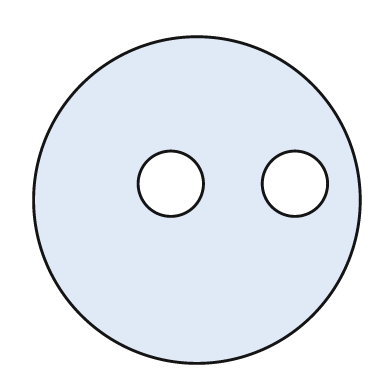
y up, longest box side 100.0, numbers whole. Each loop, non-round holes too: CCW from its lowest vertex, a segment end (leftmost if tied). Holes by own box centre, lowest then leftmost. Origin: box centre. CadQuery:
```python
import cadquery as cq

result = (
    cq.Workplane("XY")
    .moveTo(0.0, 0.0)
    .circle(50.0)
    .moveTo(-8.0, 5.0)
    .circle(10.0)
    .moveTo(30.0, 5.0)
    .circle(10.0)
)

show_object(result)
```